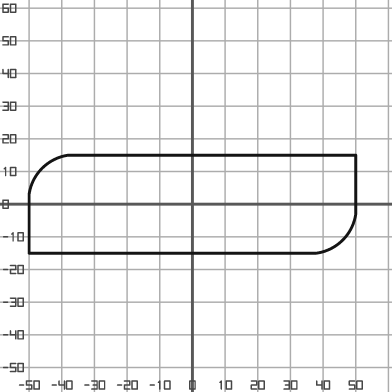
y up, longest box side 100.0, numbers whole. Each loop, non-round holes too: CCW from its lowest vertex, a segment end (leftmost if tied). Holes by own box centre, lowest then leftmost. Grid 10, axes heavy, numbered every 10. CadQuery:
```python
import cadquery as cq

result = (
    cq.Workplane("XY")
    .moveTo(-50.0, -15.0)
    .lineTo(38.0, -15.0)
    .threePointArc((46.0, -11.0), (50.0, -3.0))
    .lineTo(50.0, 15.0)
    .lineTo(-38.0, 15.0)
    .threePointArc((-46.0, 11.0), (-50.0, 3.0))
    .close()
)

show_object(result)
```